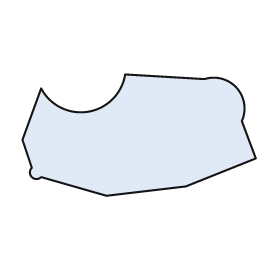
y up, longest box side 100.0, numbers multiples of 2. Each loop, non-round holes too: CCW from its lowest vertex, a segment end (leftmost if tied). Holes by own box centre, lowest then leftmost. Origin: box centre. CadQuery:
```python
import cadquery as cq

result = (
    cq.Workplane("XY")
    .moveTo(-14.0, -26.0)
    .lineTo(20.0, -22.0)
    .lineTo(50.0, -10.0)
    .lineTo(44.0, 6.0)
    .threePointArc((42.0, 20.0), (28.0, 24.0))
    .lineTo(-6.0, 26.0)
    .threePointArc((-22.0, 10.0), (-42.0, 20.0))
    .lineTo(-50.0, -2.0)
    .lineTo(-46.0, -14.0)
    .threePointArc((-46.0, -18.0), (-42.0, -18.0))
    .close()
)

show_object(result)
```